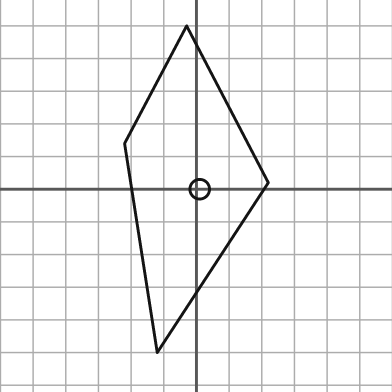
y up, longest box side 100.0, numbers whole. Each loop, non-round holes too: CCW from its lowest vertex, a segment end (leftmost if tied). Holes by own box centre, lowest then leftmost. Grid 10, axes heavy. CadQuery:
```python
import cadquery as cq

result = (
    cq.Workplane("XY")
    .moveTo(-12.0, -50.0)
    .lineTo(22.0, 2.0)
    .lineTo(-3.0, 50.0)
    .lineTo(-22.0, 14.0)
    .close()
    .moveTo(1.0, 0.0)
    .circle(3.0)
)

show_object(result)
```